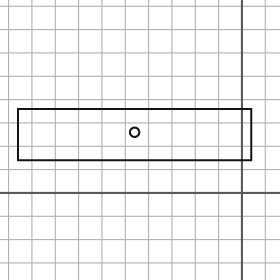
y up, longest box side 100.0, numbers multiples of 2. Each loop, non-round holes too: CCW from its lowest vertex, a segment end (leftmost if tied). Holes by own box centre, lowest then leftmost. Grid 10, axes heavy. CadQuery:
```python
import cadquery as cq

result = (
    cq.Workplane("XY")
    .moveTo(-96.0, 14.0)
    .lineTo(4.0, 14.0)
    .lineTo(4.0, 36.0)
    .lineTo(-96.0, 36.0)
    .close()
    .moveTo(-46.0, 26.0)
    .circle(2.0)
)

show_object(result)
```